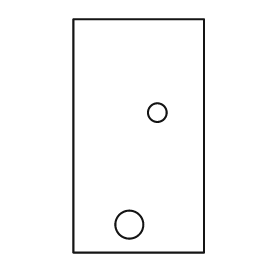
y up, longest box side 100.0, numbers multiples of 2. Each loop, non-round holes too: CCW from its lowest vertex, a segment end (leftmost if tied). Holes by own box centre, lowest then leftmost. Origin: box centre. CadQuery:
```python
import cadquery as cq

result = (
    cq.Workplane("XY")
    .moveTo(-28.0, -50.0)
    .lineTo(28.0, -50.0)
    .lineTo(28.0, 50.0)
    .lineTo(-28.0, 50.0)
    .close()
    .moveTo(-4.0, -38.0)
    .circle(6.0)
    .moveTo(8.0, 10.0)
    .circle(4.0)
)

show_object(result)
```